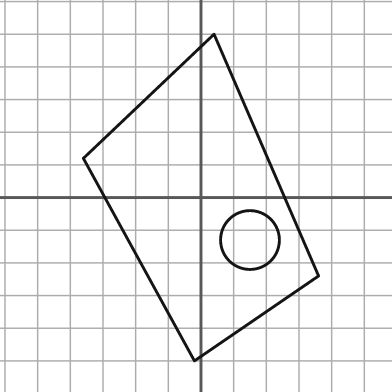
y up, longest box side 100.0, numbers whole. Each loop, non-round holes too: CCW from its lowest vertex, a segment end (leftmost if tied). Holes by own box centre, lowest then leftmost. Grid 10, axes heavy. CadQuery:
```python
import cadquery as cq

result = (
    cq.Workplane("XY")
    .moveTo(-2.0, -50.0)
    .lineTo(36.0, -24.0)
    .lineTo(4.0, 50.0)
    .lineTo(-36.0, 12.0)
    .close()
    .moveTo(15.0, -13.0)
    .circle(9.0)
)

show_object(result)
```